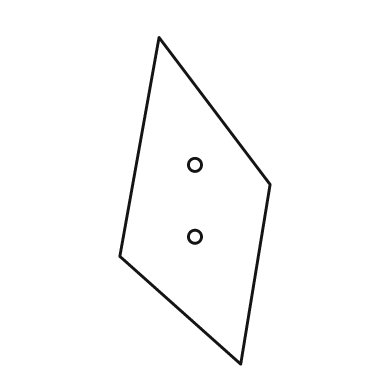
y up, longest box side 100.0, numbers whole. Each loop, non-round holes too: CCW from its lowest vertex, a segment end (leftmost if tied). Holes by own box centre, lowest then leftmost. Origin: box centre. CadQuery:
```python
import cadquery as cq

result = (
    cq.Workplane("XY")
    .moveTo(14.0, -50.0)
    .lineTo(23.0, 5.0)
    .lineTo(-11.0, 50.0)
    .lineTo(-23.0, -17.0)
    .close()
    .moveTo(0.0, -11.0)
    .circle(2.0)
    .moveTo(0.0, 11.0)
    .circle(2.0)
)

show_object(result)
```